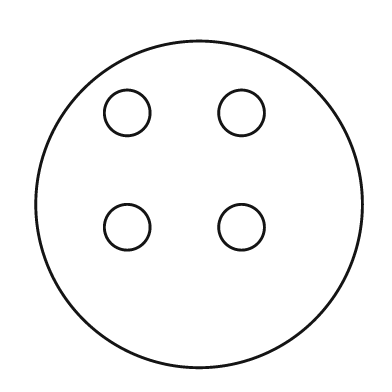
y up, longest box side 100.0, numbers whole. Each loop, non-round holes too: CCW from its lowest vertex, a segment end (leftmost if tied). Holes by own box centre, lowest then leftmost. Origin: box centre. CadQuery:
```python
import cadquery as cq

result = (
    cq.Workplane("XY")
    .moveTo(0.0, 0.0)
    .circle(50.0)
    .moveTo(-22.0, -7.0)
    .circle(7.0)
    .moveTo(13.0, -7.0)
    .circle(7.0)
    .moveTo(-22.0, 28.0)
    .circle(7.0)
    .moveTo(13.0, 28.0)
    .circle(7.0)
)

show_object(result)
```